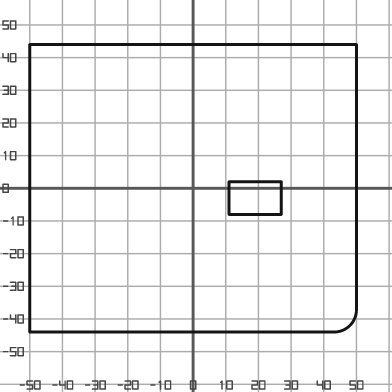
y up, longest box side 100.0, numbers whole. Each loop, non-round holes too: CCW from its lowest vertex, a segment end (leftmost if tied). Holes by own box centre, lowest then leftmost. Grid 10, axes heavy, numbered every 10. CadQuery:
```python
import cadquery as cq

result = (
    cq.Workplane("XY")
    .moveTo(-50.0, -44.0)
    .lineTo(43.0, -44.0)
    .threePointArc((48.0, -42.0), (50.0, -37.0))
    .lineTo(50.0, 44.0)
    .lineTo(-50.0, 44.0)
    .close()
    .moveTo(11.0, -8.0)
    .lineTo(27.0, -8.0)
    .lineTo(27.0, 2.0)
    .lineTo(11.0, 2.0)
    .close()
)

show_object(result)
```